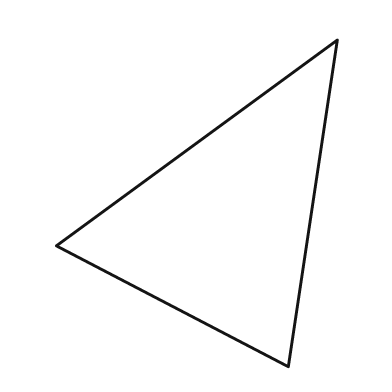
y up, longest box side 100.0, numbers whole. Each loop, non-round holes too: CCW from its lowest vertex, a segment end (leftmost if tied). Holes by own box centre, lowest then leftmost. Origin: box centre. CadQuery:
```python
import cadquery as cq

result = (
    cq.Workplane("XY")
    .moveTo(28.0, -50.0)
    .lineTo(43.0, 50.0)
    .lineTo(-43.0, -13.0)
    .close()
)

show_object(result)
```